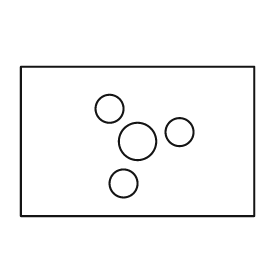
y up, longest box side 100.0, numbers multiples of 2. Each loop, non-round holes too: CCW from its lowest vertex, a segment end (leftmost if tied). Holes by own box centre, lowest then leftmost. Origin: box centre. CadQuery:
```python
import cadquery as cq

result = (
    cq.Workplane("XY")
    .moveTo(-50.0, -32.0)
    .lineTo(50.0, -32.0)
    .lineTo(50.0, 32.0)
    .lineTo(-50.0, 32.0)
    .close()
    .moveTo(-6.0, -18.0)
    .circle(6.0)
    .moveTo(0.0, 0.0)
    .circle(8.0)
    .moveTo(18.0, 4.0)
    .circle(6.0)
    .moveTo(-12.0, 14.0)
    .circle(6.0)
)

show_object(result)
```